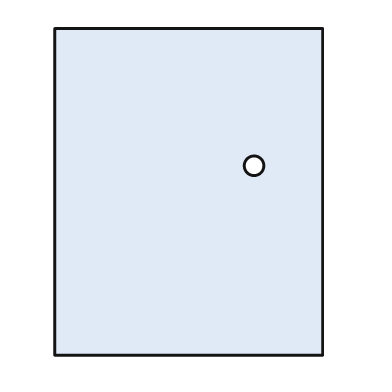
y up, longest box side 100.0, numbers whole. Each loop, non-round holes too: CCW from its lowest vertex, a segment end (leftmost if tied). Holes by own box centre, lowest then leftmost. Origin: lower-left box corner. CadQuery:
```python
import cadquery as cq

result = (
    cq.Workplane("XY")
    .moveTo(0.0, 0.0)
    .lineTo(82.0, 0.0)
    .lineTo(82.0, 100.0)
    .lineTo(0.0, 100.0)
    .close()
    .moveTo(61.0, 58.0)
    .circle(3.0)
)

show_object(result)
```